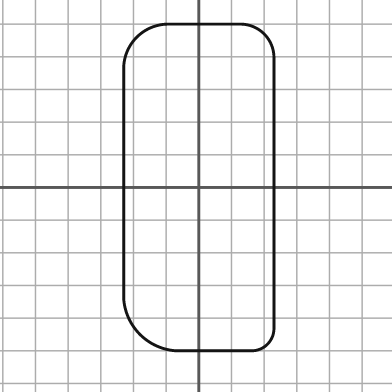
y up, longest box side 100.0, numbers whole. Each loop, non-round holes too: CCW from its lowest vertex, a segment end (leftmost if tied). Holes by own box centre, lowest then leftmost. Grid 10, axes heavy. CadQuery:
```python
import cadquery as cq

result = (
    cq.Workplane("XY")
    .moveTo(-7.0, -50.0)
    .lineTo(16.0, -50.0)
    .threePointArc((21.0, -48.0), (23.0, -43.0))
    .lineTo(23.0, 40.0)
    .threePointArc((20.0, 47.0), (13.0, 50.0))
    .lineTo(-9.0, 50.0)
    .threePointArc((-19.0, 46.0), (-23.0, 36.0))
    .lineTo(-23.0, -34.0)
    .threePointArc((-18.0, -45.0), (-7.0, -50.0))
    .close()
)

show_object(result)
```